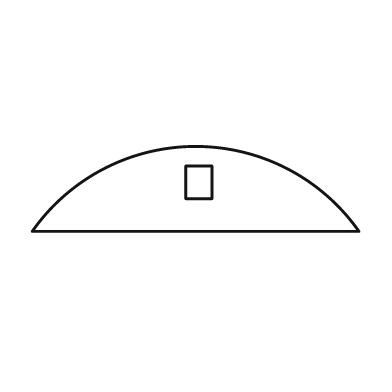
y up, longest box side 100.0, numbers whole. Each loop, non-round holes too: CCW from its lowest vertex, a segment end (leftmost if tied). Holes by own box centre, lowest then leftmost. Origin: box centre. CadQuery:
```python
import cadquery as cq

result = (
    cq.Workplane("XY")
    .moveTo(-50.0, -13.0)
    .lineTo(50.0, -13.0)
    .threePointArc((0.0, 13.0), (-50.0, -13.0))
    .close()
    .moveTo(-3.0, -3.0)
    .lineTo(5.0, -3.0)
    .lineTo(5.0, 7.0)
    .lineTo(-3.0, 7.0)
    .close()
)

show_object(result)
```